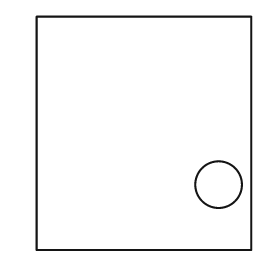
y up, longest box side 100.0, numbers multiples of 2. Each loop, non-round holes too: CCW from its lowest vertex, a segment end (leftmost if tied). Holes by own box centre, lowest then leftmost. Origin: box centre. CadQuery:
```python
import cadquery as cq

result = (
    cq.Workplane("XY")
    .moveTo(-46.0, -50.0)
    .lineTo(46.0, -50.0)
    .lineTo(46.0, 50.0)
    .lineTo(-46.0, 50.0)
    .close()
    .moveTo(32.0, -22.0)
    .circle(10.0)
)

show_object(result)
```